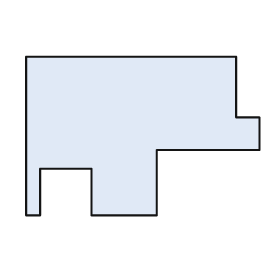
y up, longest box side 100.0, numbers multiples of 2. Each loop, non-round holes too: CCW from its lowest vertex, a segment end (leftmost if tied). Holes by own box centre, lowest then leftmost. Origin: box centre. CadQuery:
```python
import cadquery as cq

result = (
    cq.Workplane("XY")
    .moveTo(-50.0, -34.0)
    .lineTo(-44.0, -34.0)
    .lineTo(-44.0, -14.0)
    .lineTo(-22.0, -14.0)
    .lineTo(-22.0, -34.0)
    .lineTo(6.0, -34.0)
    .lineTo(6.0, -6.0)
    .lineTo(50.0, -6.0)
    .lineTo(50.0, 8.0)
    .lineTo(40.0, 8.0)
    .lineTo(40.0, 34.0)
    .lineTo(-50.0, 34.0)
    .close()
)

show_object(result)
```